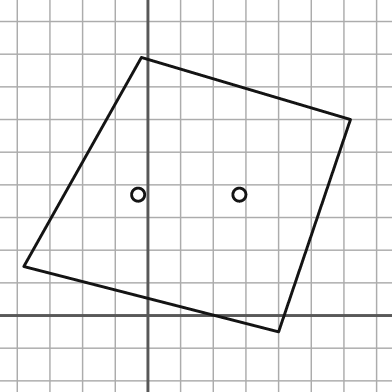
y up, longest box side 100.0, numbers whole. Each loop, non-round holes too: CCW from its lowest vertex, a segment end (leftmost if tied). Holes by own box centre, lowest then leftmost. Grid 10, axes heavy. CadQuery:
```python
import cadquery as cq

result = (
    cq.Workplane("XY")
    .moveTo(40.0, -5.0)
    .lineTo(62.0, 60.0)
    .lineTo(-2.0, 79.0)
    .lineTo(-38.0, 15.0)
    .close()
    .moveTo(-3.0, 37.0)
    .circle(2.0)
    .moveTo(28.0, 37.0)
    .circle(2.0)
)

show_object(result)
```